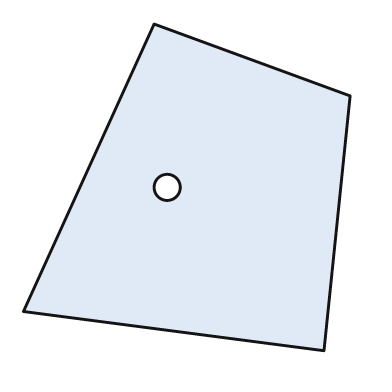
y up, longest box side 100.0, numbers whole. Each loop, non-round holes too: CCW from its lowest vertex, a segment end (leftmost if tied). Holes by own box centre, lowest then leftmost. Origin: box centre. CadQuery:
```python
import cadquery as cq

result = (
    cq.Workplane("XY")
    .moveTo(42.0, -50.0)
    .lineTo(50.0, 28.0)
    .lineTo(-10.0, 50.0)
    .lineTo(-50.0, -38.0)
    .close()
    .moveTo(-6.0, 0.0)
    .circle(4.0)
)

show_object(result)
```